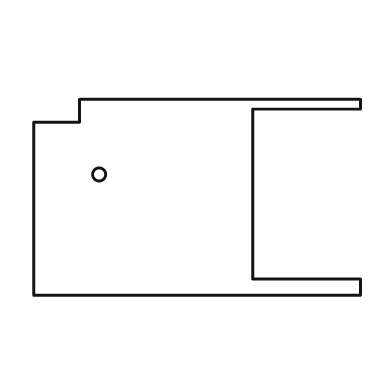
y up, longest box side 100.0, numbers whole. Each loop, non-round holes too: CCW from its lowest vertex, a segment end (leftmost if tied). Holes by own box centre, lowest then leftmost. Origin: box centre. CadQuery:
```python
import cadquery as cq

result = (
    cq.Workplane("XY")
    .moveTo(-50.0, -30.0)
    .lineTo(50.0, -30.0)
    .lineTo(50.0, -25.0)
    .lineTo(17.0, -25.0)
    .lineTo(17.0, 27.0)
    .lineTo(50.0, 27.0)
    .lineTo(50.0, 30.0)
    .lineTo(-36.0, 30.0)
    .lineTo(-36.0, 23.0)
    .lineTo(-50.0, 23.0)
    .close()
    .moveTo(-30.0, 7.0)
    .circle(2.0)
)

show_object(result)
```